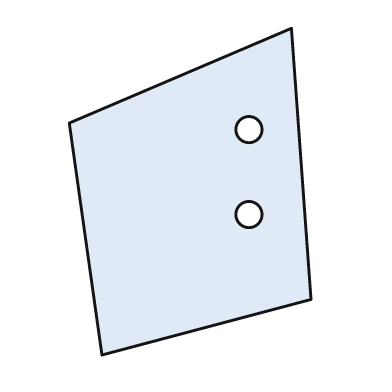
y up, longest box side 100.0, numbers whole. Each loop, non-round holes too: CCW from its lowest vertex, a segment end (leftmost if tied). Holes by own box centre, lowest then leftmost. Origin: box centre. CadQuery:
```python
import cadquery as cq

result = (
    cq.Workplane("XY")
    .moveTo(-27.0, -50.0)
    .lineTo(37.0, -33.0)
    .lineTo(31.0, 50.0)
    .lineTo(-37.0, 21.0)
    .close()
    .moveTo(18.0, -7.0)
    .circle(4.0)
    .moveTo(18.0, 19.0)
    .circle(4.0)
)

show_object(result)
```